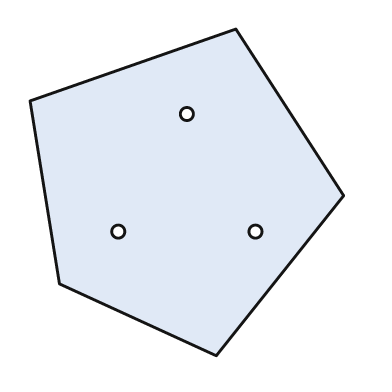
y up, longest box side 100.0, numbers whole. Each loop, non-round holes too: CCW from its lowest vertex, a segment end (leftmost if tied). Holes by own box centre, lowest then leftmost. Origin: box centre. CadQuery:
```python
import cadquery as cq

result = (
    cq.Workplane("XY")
    .moveTo(9.0, -50.0)
    .lineTo(48.0, -1.0)
    .lineTo(15.0, 50.0)
    .lineTo(-48.0, 28.0)
    .lineTo(-39.0, -28.0)
    .close()
    .moveTo(-21.0, -12.0)
    .circle(2.0)
    .moveTo(21.0, -12.0)
    .circle(2.0)
    .moveTo(0.0, 24.0)
    .circle(2.0)
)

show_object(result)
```